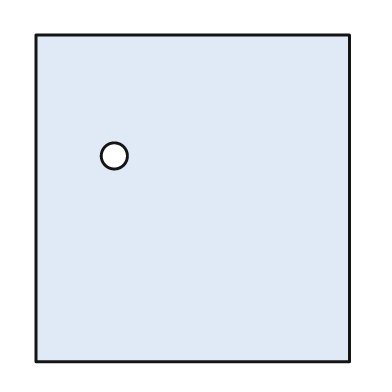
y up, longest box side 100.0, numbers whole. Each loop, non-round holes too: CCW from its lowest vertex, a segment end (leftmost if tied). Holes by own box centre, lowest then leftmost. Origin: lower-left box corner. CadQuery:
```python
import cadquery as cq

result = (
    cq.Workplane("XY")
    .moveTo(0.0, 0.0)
    .lineTo(96.0, 0.0)
    .lineTo(96.0, 100.0)
    .lineTo(0.0, 100.0)
    .close()
    .moveTo(24.0, 63.0)
    .circle(4.0)
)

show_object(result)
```